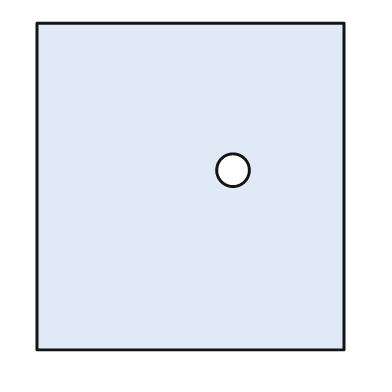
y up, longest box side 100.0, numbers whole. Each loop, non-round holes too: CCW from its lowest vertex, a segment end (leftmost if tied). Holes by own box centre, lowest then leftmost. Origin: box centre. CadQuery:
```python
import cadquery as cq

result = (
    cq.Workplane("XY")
    .moveTo(-47.0, -50.0)
    .lineTo(47.0, -50.0)
    .lineTo(47.0, 50.0)
    .lineTo(-47.0, 50.0)
    .close()
    .moveTo(13.0, 5.0)
    .circle(5.0)
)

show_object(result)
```